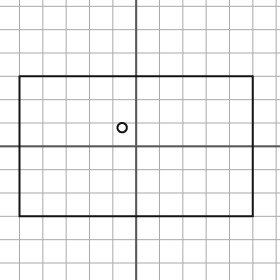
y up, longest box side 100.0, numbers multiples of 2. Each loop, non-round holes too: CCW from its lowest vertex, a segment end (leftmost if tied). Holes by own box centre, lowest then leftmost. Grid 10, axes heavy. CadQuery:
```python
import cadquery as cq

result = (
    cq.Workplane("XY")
    .moveTo(-50.0, -30.0)
    .lineTo(50.0, -30.0)
    .lineTo(50.0, 30.0)
    .lineTo(-50.0, 30.0)
    .close()
    .moveTo(-6.0, 8.0)
    .circle(2.0)
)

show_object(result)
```